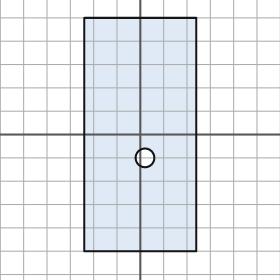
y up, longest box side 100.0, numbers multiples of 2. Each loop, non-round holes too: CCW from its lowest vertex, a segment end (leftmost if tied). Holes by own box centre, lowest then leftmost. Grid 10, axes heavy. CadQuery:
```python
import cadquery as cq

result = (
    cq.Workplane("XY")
    .moveTo(-24.0, -50.0)
    .lineTo(24.0, -50.0)
    .lineTo(24.0, 50.0)
    .lineTo(-24.0, 50.0)
    .close()
    .moveTo(2.0, -10.0)
    .circle(4.0)
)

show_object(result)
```